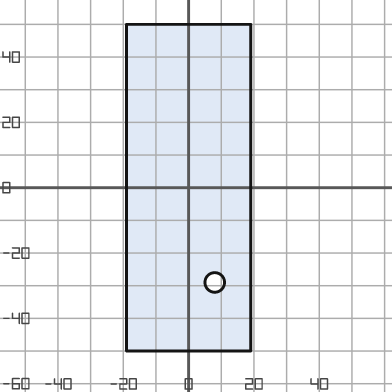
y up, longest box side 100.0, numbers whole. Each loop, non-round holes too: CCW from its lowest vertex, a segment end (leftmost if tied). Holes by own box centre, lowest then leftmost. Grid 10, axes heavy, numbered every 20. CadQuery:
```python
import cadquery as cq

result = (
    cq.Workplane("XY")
    .moveTo(-19.0, -50.0)
    .lineTo(19.0, -50.0)
    .lineTo(19.0, 50.0)
    .lineTo(-19.0, 50.0)
    .close()
    .moveTo(8.0, -29.0)
    .circle(3.0)
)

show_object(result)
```